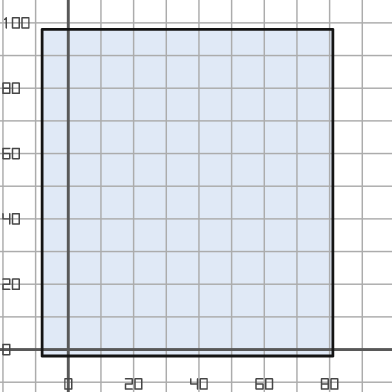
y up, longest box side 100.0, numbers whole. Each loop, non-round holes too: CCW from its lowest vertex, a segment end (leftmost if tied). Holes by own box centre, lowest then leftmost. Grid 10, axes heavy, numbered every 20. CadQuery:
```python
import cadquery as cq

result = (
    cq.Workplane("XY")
    .moveTo(-8.0, -2.0)
    .lineTo(81.0, -2.0)
    .lineTo(81.0, 98.0)
    .lineTo(-8.0, 98.0)
    .close()
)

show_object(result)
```